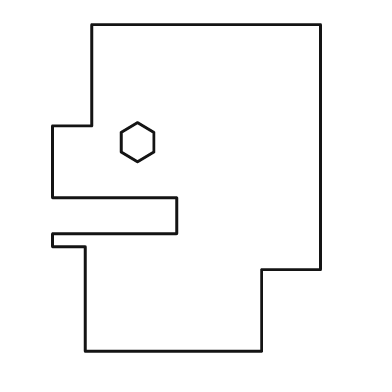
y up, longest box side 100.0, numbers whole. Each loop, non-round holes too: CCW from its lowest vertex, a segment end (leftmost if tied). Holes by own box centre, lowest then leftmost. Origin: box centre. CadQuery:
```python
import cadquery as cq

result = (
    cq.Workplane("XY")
    .moveTo(-31.0, -50.0)
    .lineTo(23.0, -50.0)
    .lineTo(23.0, -25.0)
    .lineTo(41.0, -25.0)
    .lineTo(41.0, 50.0)
    .lineTo(-29.0, 50.0)
    .lineTo(-29.0, 19.0)
    .lineTo(-41.0, 19.0)
    .lineTo(-41.0, -3.0)
    .lineTo(-3.0, -3.0)
    .lineTo(-3.0, -14.0)
    .lineTo(-41.0, -14.0)
    .lineTo(-41.0, -18.0)
    .lineTo(-31.0, -18.0)
    .close()
    .moveTo(-15.0, 8.0)
    .lineTo(-10.0, 11.0)
    .lineTo(-10.0, 17.0)
    .lineTo(-15.0, 20.0)
    .lineTo(-20.0, 17.0)
    .lineTo(-20.0, 11.0)
    .close()
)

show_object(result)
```